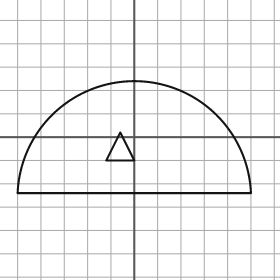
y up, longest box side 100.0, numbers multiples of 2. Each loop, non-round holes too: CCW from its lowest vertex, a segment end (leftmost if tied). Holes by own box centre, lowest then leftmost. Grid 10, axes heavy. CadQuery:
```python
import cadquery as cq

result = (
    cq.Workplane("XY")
    .moveTo(-50.0, -24.0)
    .lineTo(50.0, -24.0)
    .threePointArc((0.0, 24.0), (-50.0, -24.0))
    .close()
    .moveTo(-12.0, -10.0)
    .lineTo(0.0, -10.0)
    .lineTo(-6.0, 2.0)
    .close()
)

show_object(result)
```